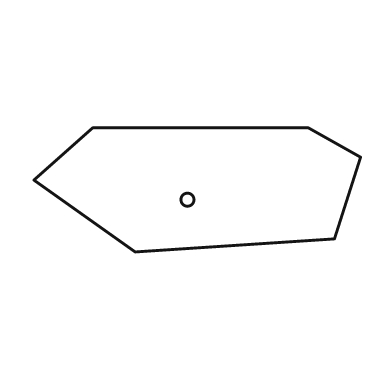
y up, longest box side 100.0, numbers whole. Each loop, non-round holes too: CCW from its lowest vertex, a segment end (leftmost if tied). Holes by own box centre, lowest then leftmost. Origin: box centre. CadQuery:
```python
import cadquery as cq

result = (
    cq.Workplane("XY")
    .moveTo(-19.0, -19.0)
    .lineTo(42.0, -15.0)
    .lineTo(50.0, 10.0)
    .lineTo(34.0, 19.0)
    .lineTo(-32.0, 19.0)
    .lineTo(-50.0, 3.0)
    .close()
    .moveTo(-3.0, -3.0)
    .circle(2.0)
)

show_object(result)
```